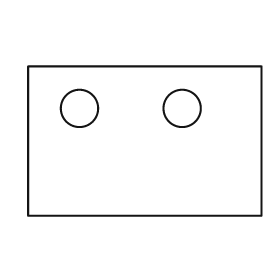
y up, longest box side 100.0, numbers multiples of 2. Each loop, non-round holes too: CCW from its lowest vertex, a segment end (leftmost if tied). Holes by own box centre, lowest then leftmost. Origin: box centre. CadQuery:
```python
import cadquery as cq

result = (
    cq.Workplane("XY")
    .moveTo(-50.0, -32.0)
    .lineTo(50.0, -32.0)
    .lineTo(50.0, 32.0)
    .lineTo(-50.0, 32.0)
    .close()
    .moveTo(-28.0, 14.0)
    .circle(8.0)
    .moveTo(16.0, 14.0)
    .circle(8.0)
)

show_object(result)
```